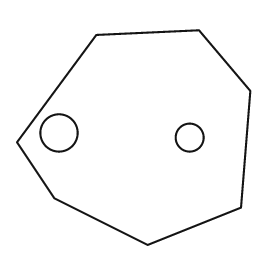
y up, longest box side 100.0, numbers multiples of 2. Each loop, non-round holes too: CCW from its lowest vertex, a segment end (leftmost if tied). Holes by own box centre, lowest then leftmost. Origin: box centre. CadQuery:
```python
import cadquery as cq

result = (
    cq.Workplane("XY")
    .moveTo(6.0, -46.0)
    .lineTo(46.0, -30.0)
    .lineTo(50.0, 20.0)
    .lineTo(28.0, 46.0)
    .lineTo(-16.0, 44.0)
    .lineTo(-50.0, -2.0)
    .lineTo(-34.0, -26.0)
    .close()
    .moveTo(24.0, 0.0)
    .circle(6.0)
    .moveTo(-32.0, 2.0)
    .circle(8.0)
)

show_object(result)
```